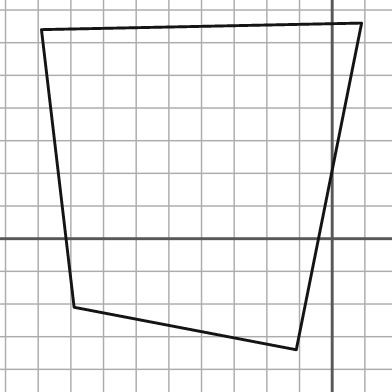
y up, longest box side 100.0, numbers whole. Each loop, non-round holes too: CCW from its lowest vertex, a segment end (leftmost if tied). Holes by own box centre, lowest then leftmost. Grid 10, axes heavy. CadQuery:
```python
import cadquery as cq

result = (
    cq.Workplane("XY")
    .moveTo(-11.0, -34.0)
    .lineTo(9.0, 66.0)
    .lineTo(-89.0, 64.0)
    .lineTo(-79.0, -21.0)
    .close()
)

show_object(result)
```